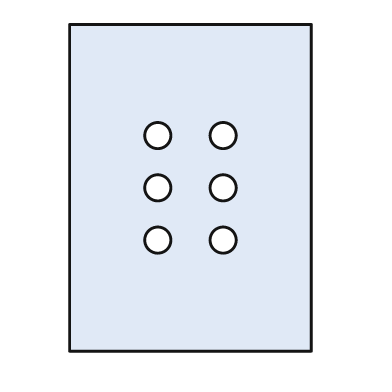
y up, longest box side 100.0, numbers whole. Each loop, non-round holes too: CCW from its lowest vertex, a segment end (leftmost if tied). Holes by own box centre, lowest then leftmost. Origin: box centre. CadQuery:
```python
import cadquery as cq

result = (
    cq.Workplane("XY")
    .moveTo(-37.0, -50.0)
    .lineTo(37.0, -50.0)
    .lineTo(37.0, 50.0)
    .lineTo(-37.0, 50.0)
    .close()
    .moveTo(-10.0, -16.0)
    .circle(4.0)
    .moveTo(10.0, -16.0)
    .circle(4.0)
    .moveTo(-10.0, 0.0)
    .circle(4.0)
    .moveTo(10.0, 0.0)
    .circle(4.0)
    .moveTo(-10.0, 16.0)
    .circle(4.0)
    .moveTo(10.0, 16.0)
    .circle(4.0)
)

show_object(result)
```